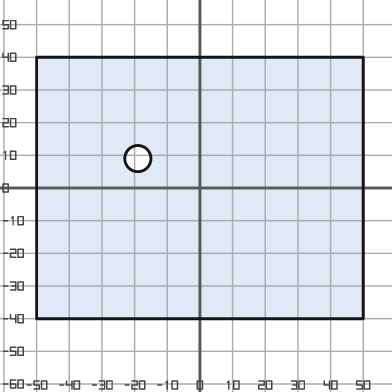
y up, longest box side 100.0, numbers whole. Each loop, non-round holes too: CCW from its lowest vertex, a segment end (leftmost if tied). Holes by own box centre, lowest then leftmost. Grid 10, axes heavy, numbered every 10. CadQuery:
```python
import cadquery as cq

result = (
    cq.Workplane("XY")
    .moveTo(-50.0, -40.0)
    .lineTo(50.0, -40.0)
    .lineTo(50.0, 40.0)
    .lineTo(-50.0, 40.0)
    .close()
    .moveTo(-19.0, 9.0)
    .circle(4.0)
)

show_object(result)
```